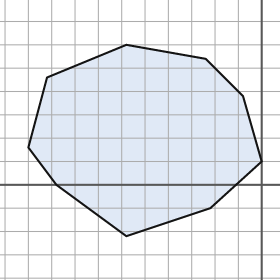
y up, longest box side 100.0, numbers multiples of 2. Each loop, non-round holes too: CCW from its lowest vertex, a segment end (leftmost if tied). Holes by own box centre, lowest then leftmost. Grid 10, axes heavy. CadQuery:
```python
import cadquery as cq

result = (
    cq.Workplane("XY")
    .moveTo(-58.0, -22.0)
    .lineTo(-22.0, -10.0)
    .lineTo(0.0, 10.0)
    .lineTo(-8.0, 38.0)
    .lineTo(-24.0, 54.0)
    .lineTo(-58.0, 60.0)
    .lineTo(-92.0, 46.0)
    .lineTo(-100.0, 16.0)
    .lineTo(-88.0, 0.0)
    .close()
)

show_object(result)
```